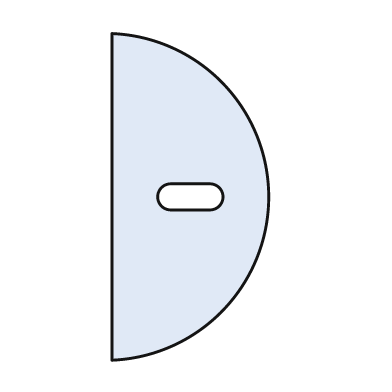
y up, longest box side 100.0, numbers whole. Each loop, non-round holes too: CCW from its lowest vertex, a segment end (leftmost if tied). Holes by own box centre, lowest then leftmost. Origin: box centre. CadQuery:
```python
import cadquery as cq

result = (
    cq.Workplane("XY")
    .moveTo(-24.0, -50.0)
    .threePointArc((24.0, 0.0), (-24.0, 50.0))
    .close()
    .moveTo(-6.0, -4.0)
    .lineTo(6.0, -4.0)
    .threePointArc((10.0, 0.0), (6.0, 4.0))
    .lineTo(-6.0, 4.0)
    .threePointArc((-10.0, 0.0), (-6.0, -4.0))
    .close()
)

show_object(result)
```